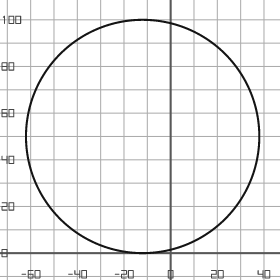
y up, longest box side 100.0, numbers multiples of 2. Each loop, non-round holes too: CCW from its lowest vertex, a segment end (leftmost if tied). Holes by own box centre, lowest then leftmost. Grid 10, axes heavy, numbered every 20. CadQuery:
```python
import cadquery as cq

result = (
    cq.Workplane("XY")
    .moveTo(-12.0, 50.0)
    .circle(50.0)
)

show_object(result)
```